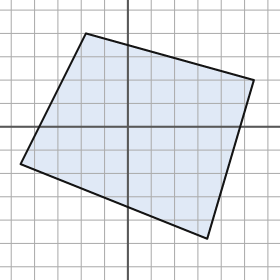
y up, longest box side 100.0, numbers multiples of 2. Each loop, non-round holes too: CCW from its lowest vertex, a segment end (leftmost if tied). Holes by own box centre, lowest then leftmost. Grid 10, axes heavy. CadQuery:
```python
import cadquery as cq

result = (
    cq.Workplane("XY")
    .moveTo(34.0, -48.0)
    .lineTo(54.0, 20.0)
    .lineTo(-18.0, 40.0)
    .lineTo(-46.0, -16.0)
    .close()
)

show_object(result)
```